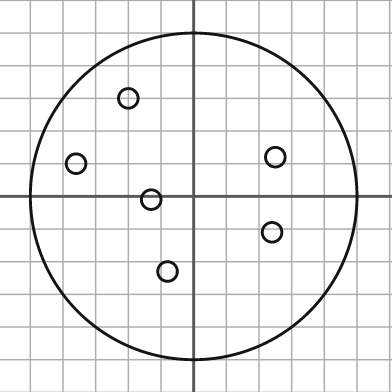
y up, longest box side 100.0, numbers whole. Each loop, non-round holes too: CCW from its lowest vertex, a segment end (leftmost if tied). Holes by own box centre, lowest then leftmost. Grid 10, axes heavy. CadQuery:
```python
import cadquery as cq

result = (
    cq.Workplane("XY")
    .moveTo(0.0, 0.0)
    .circle(50.0)
    .moveTo(-8.0, -23.0)
    .circle(3.0)
    .moveTo(24.0, -11.0)
    .circle(3.0)
    .moveTo(-13.0, -1.0)
    .circle(3.0)
    .moveTo(-36.0, 10.0)
    .circle(3.0)
    .moveTo(25.0, 12.0)
    .circle(3.0)
    .moveTo(-20.0, 30.0)
    .circle(3.0)
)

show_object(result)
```